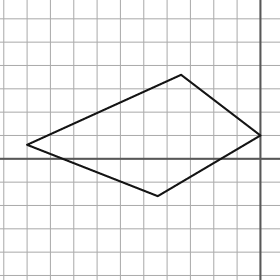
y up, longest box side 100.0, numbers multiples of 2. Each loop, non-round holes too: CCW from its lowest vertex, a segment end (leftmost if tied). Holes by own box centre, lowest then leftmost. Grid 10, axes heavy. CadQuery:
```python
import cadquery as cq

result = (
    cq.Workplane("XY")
    .moveTo(-44.0, -16.0)
    .lineTo(0.0, 10.0)
    .lineTo(-34.0, 36.0)
    .lineTo(-100.0, 6.0)
    .close()
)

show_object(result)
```